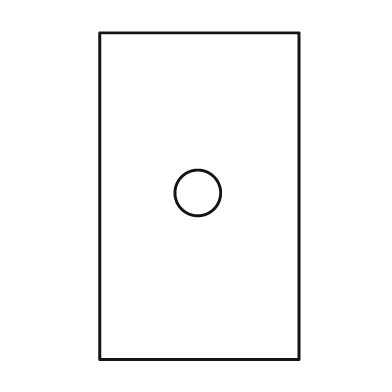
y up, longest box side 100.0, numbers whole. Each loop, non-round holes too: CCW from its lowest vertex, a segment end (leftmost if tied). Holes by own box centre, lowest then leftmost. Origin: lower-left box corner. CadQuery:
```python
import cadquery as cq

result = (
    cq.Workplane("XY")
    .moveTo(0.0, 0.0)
    .lineTo(61.0, 0.0)
    .lineTo(61.0, 100.0)
    .lineTo(0.0, 100.0)
    .close()
    .moveTo(30.0, 51.0)
    .circle(7.0)
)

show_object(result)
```